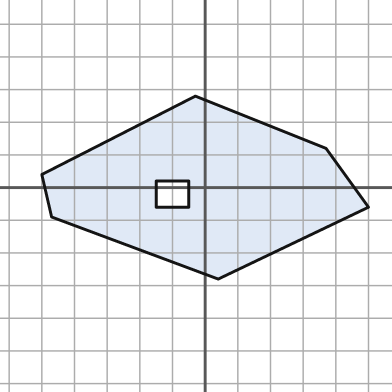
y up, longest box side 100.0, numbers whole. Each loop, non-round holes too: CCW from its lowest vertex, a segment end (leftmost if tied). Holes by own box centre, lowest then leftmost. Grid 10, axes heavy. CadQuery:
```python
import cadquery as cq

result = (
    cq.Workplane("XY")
    .moveTo(4.0, -28.0)
    .lineTo(50.0, -6.0)
    .lineTo(37.0, 12.0)
    .lineTo(-3.0, 28.0)
    .lineTo(-50.0, 4.0)
    .lineTo(-47.0, -9.0)
    .close()
    .moveTo(-15.0, -6.0)
    .lineTo(-5.0, -6.0)
    .lineTo(-5.0, 2.0)
    .lineTo(-15.0, 2.0)
    .close()
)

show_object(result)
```